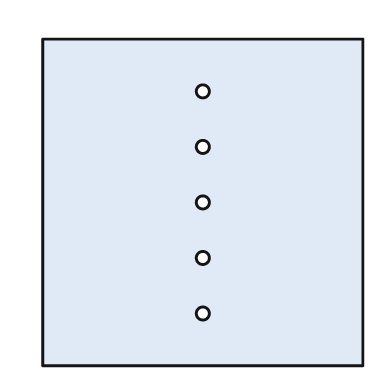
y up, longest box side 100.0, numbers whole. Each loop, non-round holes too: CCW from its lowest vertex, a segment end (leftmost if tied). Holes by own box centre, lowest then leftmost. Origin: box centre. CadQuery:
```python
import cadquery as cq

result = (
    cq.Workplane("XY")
    .moveTo(-49.0, -50.0)
    .lineTo(49.0, -50.0)
    .lineTo(49.0, 50.0)
    .lineTo(-49.0, 50.0)
    .close()
    .moveTo(0.0, -34.0)
    .circle(2.0)
    .moveTo(0.0, -17.0)
    .circle(2.0)
    .moveTo(0.0, 0.0)
    .circle(2.0)
    .moveTo(0.0, 17.0)
    .circle(2.0)
    .moveTo(0.0, 34.0)
    .circle(2.0)
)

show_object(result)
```